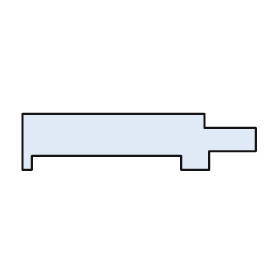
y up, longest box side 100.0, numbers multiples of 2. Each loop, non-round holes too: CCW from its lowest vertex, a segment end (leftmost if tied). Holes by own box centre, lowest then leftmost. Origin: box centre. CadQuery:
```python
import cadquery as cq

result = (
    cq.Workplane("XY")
    .moveTo(-50.0, -12.0)
    .lineTo(-46.0, -12.0)
    .lineTo(-46.0, -6.0)
    .lineTo(18.0, -6.0)
    .lineTo(18.0, -12.0)
    .lineTo(30.0, -12.0)
    .lineTo(30.0, -4.0)
    .lineTo(50.0, -4.0)
    .lineTo(50.0, 6.0)
    .lineTo(28.0, 6.0)
    .lineTo(28.0, 12.0)
    .lineTo(-50.0, 12.0)
    .close()
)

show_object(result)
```